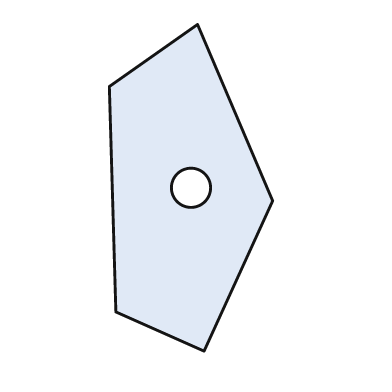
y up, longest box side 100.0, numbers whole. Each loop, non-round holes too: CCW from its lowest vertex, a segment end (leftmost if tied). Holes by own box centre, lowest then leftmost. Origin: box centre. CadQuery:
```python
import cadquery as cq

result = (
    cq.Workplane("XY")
    .moveTo(4.0, -50.0)
    .lineTo(25.0, -4.0)
    .lineTo(2.0, 50.0)
    .lineTo(-25.0, 31.0)
    .lineTo(-23.0, -38.0)
    .close()
    .moveTo(0.0, 0.0)
    .circle(6.0)
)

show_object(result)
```